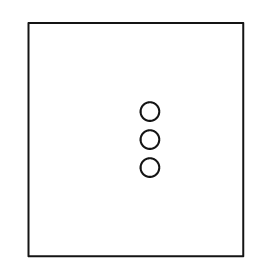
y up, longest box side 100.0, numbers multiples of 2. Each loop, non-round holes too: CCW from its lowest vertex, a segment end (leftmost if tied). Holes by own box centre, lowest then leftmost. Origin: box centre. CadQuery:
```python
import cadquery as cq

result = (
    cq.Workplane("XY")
    .moveTo(-46.0, -50.0)
    .lineTo(46.0, -50.0)
    .lineTo(46.0, 50.0)
    .lineTo(-46.0, 50.0)
    .close()
    .moveTo(6.0, -12.0)
    .circle(4.0)
    .moveTo(6.0, 0.0)
    .circle(4.0)
    .moveTo(6.0, 12.0)
    .circle(4.0)
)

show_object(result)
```